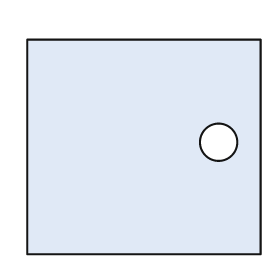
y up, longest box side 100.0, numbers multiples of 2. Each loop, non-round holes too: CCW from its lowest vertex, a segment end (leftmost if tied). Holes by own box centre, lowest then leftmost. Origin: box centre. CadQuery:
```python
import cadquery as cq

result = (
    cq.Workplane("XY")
    .moveTo(-50.0, -46.0)
    .lineTo(50.0, -46.0)
    .lineTo(50.0, 46.0)
    .lineTo(-50.0, 46.0)
    .close()
    .moveTo(32.0, 2.0)
    .circle(8.0)
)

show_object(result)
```